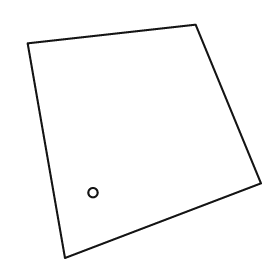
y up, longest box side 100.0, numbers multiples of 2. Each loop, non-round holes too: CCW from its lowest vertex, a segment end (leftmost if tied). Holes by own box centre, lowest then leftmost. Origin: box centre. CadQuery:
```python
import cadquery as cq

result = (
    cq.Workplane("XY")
    .moveTo(-34.0, -50.0)
    .lineTo(50.0, -18.0)
    .lineTo(22.0, 50.0)
    .lineTo(-50.0, 42.0)
    .close()
    .moveTo(-22.0, -22.0)
    .circle(2.0)
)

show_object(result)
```